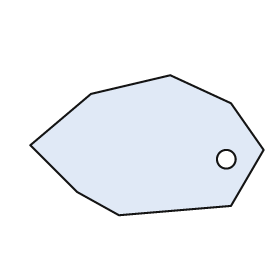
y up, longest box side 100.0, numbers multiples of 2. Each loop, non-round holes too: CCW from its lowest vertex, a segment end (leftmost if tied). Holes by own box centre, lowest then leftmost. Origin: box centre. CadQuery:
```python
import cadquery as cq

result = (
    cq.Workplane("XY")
    .moveTo(-12.0, -30.0)
    .lineTo(36.0, -26.0)
    .lineTo(50.0, -2.0)
    .lineTo(36.0, 18.0)
    .lineTo(10.0, 30.0)
    .lineTo(-24.0, 22.0)
    .lineTo(-50.0, 0.0)
    .lineTo(-30.0, -20.0)
    .close()
    .moveTo(34.0, -6.0)
    .circle(4.0)
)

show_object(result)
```